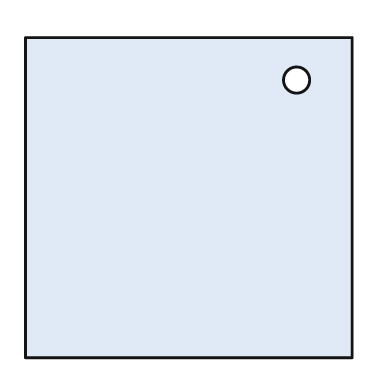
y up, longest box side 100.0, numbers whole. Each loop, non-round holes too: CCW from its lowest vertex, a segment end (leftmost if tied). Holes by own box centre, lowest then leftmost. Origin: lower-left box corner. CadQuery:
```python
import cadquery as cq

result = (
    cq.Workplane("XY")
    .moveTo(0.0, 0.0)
    .lineTo(100.0, 0.0)
    .lineTo(100.0, 98.0)
    .lineTo(0.0, 98.0)
    .close()
    .moveTo(83.0, 85.0)
    .circle(4.0)
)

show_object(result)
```